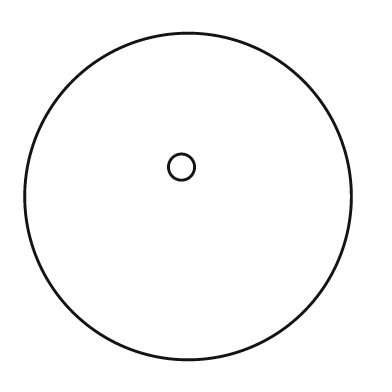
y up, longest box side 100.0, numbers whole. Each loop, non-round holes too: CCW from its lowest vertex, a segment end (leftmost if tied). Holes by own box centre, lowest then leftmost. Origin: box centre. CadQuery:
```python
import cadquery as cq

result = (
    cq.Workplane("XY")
    .moveTo(0.0, 0.0)
    .circle(50.0)
    .moveTo(-2.0, 9.0)
    .circle(4.0)
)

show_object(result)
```